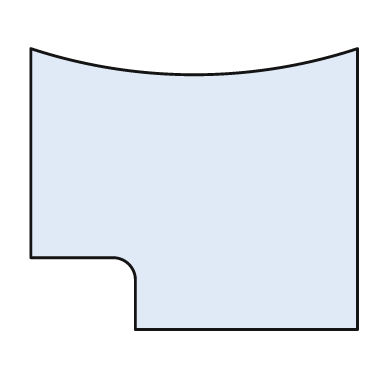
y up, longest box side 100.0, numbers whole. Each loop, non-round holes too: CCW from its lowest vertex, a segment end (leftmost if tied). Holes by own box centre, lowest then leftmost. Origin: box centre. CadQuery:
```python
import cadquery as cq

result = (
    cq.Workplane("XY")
    .moveTo(-18.0, -43.0)
    .lineTo(50.0, -43.0)
    .lineTo(50.0, 43.0)
    .threePointArc((0.0, 35.0), (-50.0, 43.0))
    .lineTo(-50.0, -21.0)
    .lineTo(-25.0, -21.0)
    .threePointArc((-20.0, -23.0), (-18.0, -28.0))
    .close()
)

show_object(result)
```